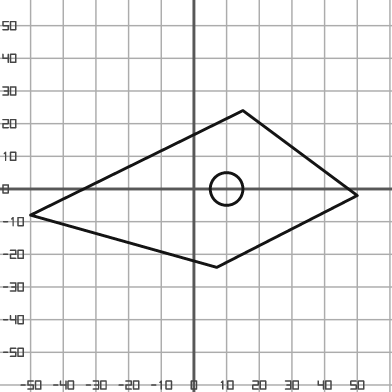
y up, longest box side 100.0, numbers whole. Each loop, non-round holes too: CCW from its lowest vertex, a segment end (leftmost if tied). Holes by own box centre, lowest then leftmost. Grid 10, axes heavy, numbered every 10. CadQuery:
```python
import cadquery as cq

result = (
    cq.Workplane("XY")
    .moveTo(7.0, -24.0)
    .lineTo(50.0, -2.0)
    .lineTo(15.0, 24.0)
    .lineTo(-50.0, -8.0)
    .close()
    .moveTo(10.0, 0.0)
    .circle(5.0)
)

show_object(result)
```